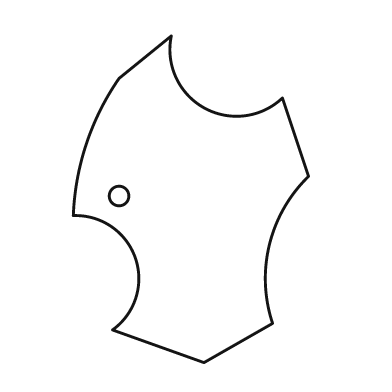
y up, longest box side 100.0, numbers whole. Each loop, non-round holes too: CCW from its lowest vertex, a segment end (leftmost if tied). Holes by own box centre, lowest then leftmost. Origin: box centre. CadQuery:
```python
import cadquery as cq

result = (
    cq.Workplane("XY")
    .moveTo(4.0, -50.0)
    .lineTo(25.0, -38.0)
    .threePointArc((24.0, -14.0), (36.0, 7.0))
    .lineTo(28.0, 31.0)
    .threePointArc((4.0, 28.0), (-6.0, 50.0))
    .lineTo(-22.0, 37.0)
    .threePointArc((-32.0, 17.0), (-36.0, -5.0))
    .threePointArc((-17.0, -18.0), (-24.0, -40.0))
    .close()
    .moveTo(-22.0, 1.0)
    .circle(3.0)
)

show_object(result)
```